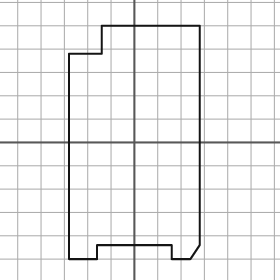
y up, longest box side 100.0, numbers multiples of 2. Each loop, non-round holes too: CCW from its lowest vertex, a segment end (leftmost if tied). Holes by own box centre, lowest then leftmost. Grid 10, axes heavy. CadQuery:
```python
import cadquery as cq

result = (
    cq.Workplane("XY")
    .moveTo(-28.0, -50.0)
    .lineTo(-16.0, -50.0)
    .lineTo(-16.0, -44.0)
    .lineTo(16.0, -44.0)
    .lineTo(16.0, -50.0)
    .lineTo(24.0, -50.0)
    .lineTo(28.0, -44.0)
    .lineTo(28.0, 50.0)
    .lineTo(-14.0, 50.0)
    .lineTo(-14.0, 38.0)
    .lineTo(-28.0, 38.0)
    .close()
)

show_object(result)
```